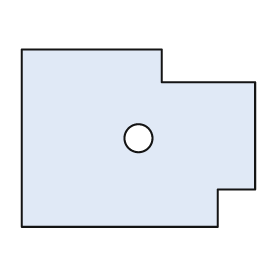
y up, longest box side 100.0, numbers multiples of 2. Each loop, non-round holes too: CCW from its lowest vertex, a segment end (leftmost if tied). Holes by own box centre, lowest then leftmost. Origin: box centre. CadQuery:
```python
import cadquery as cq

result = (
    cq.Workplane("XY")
    .moveTo(-50.0, -38.0)
    .lineTo(34.0, -38.0)
    .lineTo(34.0, -22.0)
    .lineTo(50.0, -22.0)
    .lineTo(50.0, 24.0)
    .lineTo(10.0, 24.0)
    .lineTo(10.0, 38.0)
    .lineTo(-50.0, 38.0)
    .close()
    .moveTo(0.0, 0.0)
    .circle(6.0)
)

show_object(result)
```